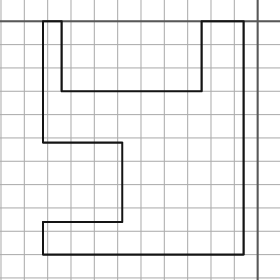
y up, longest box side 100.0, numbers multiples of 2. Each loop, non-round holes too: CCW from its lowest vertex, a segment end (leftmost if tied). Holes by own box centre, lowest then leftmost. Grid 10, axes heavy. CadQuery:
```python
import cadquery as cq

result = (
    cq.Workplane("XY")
    .moveTo(-92.0, -100.0)
    .lineTo(-6.0, -100.0)
    .lineTo(-6.0, 0.0)
    .lineTo(-24.0, 0.0)
    .lineTo(-24.0, -30.0)
    .lineTo(-84.0, -30.0)
    .lineTo(-84.0, 0.0)
    .lineTo(-92.0, 0.0)
    .lineTo(-92.0, -52.0)
    .lineTo(-58.0, -52.0)
    .lineTo(-58.0, -86.0)
    .lineTo(-92.0, -86.0)
    .close()
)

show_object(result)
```